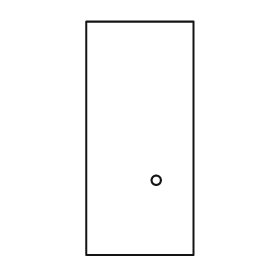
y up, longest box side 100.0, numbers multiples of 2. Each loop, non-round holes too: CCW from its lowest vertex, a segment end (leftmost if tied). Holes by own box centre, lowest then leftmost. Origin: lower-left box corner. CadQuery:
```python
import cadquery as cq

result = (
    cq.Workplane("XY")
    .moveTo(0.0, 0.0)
    .lineTo(46.0, 0.0)
    .lineTo(46.0, 100.0)
    .lineTo(0.0, 100.0)
    .close()
    .moveTo(30.0, 32.0)
    .circle(2.0)
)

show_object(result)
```